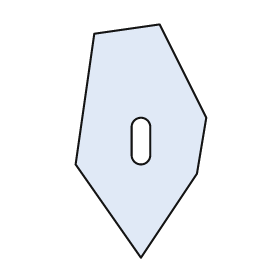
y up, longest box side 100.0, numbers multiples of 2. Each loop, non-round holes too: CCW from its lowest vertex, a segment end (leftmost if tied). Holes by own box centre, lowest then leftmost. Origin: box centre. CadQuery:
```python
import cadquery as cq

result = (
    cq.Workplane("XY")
    .moveTo(0.0, -50.0)
    .lineTo(24.0, -14.0)
    .lineTo(28.0, 10.0)
    .lineTo(8.0, 50.0)
    .lineTo(-20.0, 46.0)
    .lineTo(-28.0, -10.0)
    .close()
    .moveTo(-4.0, -6.0)
    .threePointArc((0.0, -10.0), (4.0, -6.0))
    .lineTo(4.0, 6.0)
    .threePointArc((0.0, 10.0), (-4.0, 6.0))
    .close()
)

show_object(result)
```